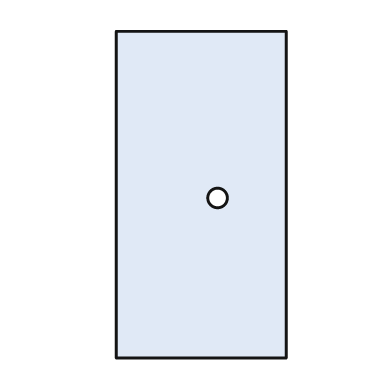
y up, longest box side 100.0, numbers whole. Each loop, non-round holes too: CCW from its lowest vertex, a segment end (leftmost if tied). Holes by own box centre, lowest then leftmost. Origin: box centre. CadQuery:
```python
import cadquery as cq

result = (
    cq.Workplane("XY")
    .moveTo(-26.0, -50.0)
    .lineTo(26.0, -50.0)
    .lineTo(26.0, 50.0)
    .lineTo(-26.0, 50.0)
    .close()
    .moveTo(5.0, -1.0)
    .circle(3.0)
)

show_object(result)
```